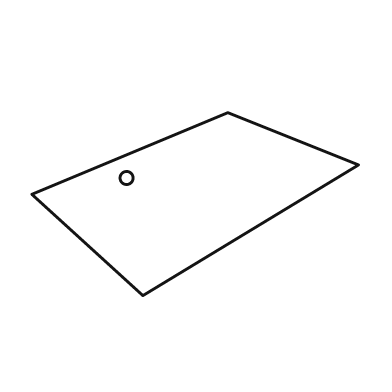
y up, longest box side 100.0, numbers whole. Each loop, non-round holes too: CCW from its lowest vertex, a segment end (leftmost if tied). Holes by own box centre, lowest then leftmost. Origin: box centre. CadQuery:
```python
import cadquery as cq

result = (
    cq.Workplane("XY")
    .moveTo(-16.0, -28.0)
    .lineTo(50.0, 12.0)
    .lineTo(10.0, 28.0)
    .lineTo(-50.0, 3.0)
    .close()
    .moveTo(-21.0, 8.0)
    .circle(2.0)
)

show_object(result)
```